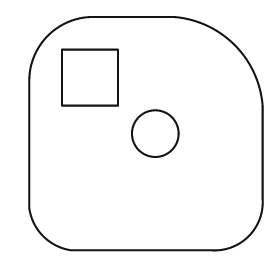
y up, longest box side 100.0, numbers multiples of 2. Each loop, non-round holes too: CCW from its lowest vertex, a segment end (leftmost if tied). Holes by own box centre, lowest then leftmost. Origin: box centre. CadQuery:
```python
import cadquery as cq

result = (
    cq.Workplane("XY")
    .moveTo(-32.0, -50.0)
    .lineTo(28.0, -50.0)
    .threePointArc((44.0, -44.0), (50.0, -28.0))
    .lineTo(50.0, 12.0)
    .threePointArc((38.0, 38.0), (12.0, 50.0))
    .lineTo(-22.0, 50.0)
    .threePointArc((-42.0, 42.0), (-50.0, 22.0))
    .lineTo(-50.0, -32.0)
    .threePointArc((-44.0, -44.0), (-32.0, -50.0))
    .close()
    .moveTo(4.0, 0.0)
    .circle(10.0)
    .moveTo(-36.0, 12.0)
    .lineTo(-12.0, 12.0)
    .lineTo(-12.0, 36.0)
    .lineTo(-36.0, 36.0)
    .close()
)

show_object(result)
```